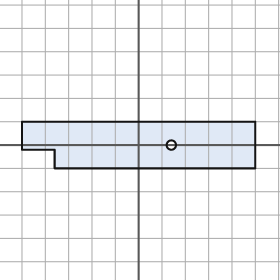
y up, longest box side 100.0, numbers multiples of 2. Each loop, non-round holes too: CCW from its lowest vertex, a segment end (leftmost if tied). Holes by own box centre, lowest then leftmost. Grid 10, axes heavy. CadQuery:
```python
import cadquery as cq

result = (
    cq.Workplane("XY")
    .moveTo(-36.0, -10.0)
    .lineTo(50.0, -10.0)
    .lineTo(50.0, 10.0)
    .lineTo(-50.0, 10.0)
    .lineTo(-50.0, -2.0)
    .lineTo(-36.0, -2.0)
    .close()
    .moveTo(14.0, 0.0)
    .circle(2.0)
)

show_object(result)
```